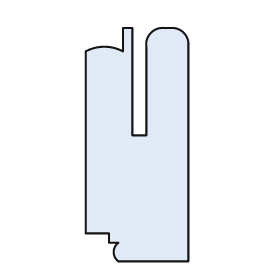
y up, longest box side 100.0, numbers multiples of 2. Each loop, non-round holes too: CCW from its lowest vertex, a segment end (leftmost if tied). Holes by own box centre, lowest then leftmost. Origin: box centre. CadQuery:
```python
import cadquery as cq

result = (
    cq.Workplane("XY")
    .moveTo(-8.0, -50.0)
    .lineTo(22.0, -50.0)
    .lineTo(22.0, 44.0)
    .threePointArc((20.0, 48.0), (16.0, 50.0))
    .lineTo(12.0, 50.0)
    .threePointArc((6.0, 48.0), (4.0, 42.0))
    .lineTo(4.0, 4.0)
    .lineTo(-2.0, 4.0)
    .lineTo(-2.0, 50.0)
    .lineTo(-6.0, 50.0)
    .lineTo(-6.0, 40.0)
    .threePointArc((-14.0, 42.0), (-22.0, 40.0))
    .lineTo(-22.0, -38.0)
    .lineTo(-12.0, -38.0)
    .lineTo(-12.0, -42.0)
    .lineTo(-8.0, -42.0)
    .threePointArc((-10.0, -46.0), (-8.0, -50.0))
    .close()
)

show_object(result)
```